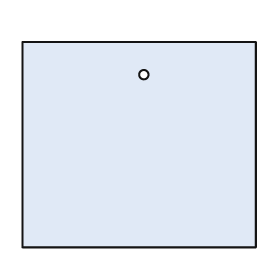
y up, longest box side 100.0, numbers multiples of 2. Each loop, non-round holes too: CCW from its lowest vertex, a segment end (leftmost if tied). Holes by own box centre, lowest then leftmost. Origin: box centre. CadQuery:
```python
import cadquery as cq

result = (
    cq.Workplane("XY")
    .moveTo(-50.0, -44.0)
    .lineTo(50.0, -44.0)
    .lineTo(50.0, 44.0)
    .lineTo(-50.0, 44.0)
    .close()
    .moveTo(2.0, 30.0)
    .circle(2.0)
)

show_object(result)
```